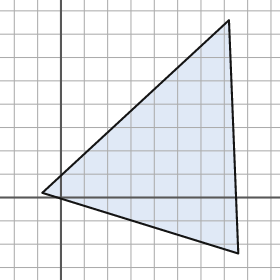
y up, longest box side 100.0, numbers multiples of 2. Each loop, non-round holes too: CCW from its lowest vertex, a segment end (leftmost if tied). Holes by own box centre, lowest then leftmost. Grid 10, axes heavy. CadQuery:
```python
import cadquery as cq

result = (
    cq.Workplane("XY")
    .moveTo(76.0, -24.0)
    .lineTo(72.0, 76.0)
    .lineTo(-8.0, 2.0)
    .close()
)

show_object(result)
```